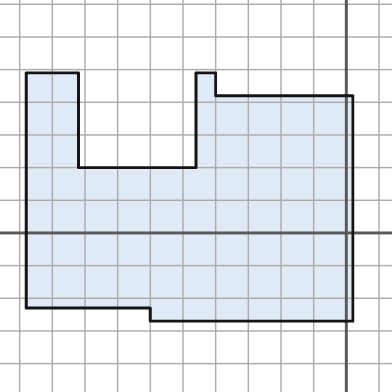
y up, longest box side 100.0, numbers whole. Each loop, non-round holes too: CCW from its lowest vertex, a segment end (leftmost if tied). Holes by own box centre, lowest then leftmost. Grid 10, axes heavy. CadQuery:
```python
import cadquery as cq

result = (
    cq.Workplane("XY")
    .moveTo(-60.0, -27.0)
    .lineTo(2.0, -27.0)
    .lineTo(2.0, 42.0)
    .lineTo(-40.0, 42.0)
    .lineTo(-40.0, 49.0)
    .lineTo(-46.0, 49.0)
    .lineTo(-46.0, 20.0)
    .lineTo(-82.0, 20.0)
    .lineTo(-82.0, 49.0)
    .lineTo(-98.0, 49.0)
    .lineTo(-98.0, -23.0)
    .lineTo(-60.0, -23.0)
    .close()
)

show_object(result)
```